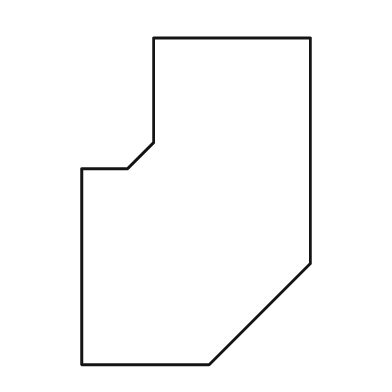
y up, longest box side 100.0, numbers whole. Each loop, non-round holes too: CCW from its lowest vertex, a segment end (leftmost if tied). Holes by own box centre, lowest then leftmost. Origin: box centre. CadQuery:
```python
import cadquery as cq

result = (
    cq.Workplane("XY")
    .moveTo(-35.0, -50.0)
    .lineTo(4.0, -50.0)
    .lineTo(35.0, -19.0)
    .lineTo(35.0, 50.0)
    .lineTo(-13.0, 50.0)
    .lineTo(-13.0, 18.0)
    .lineTo(-21.0, 10.0)
    .lineTo(-35.0, 10.0)
    .close()
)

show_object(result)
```